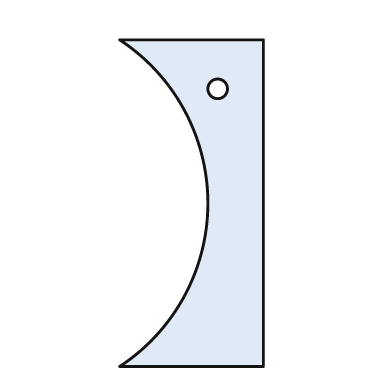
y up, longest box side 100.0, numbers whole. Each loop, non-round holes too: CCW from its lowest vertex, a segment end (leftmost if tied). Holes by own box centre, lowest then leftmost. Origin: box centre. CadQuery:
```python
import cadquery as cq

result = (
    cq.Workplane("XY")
    .moveTo(-22.0, -50.0)
    .lineTo(22.0, -50.0)
    .lineTo(22.0, 50.0)
    .lineTo(-22.0, 50.0)
    .threePointArc((5.0, 0.0), (-22.0, -50.0))
    .close()
    .moveTo(8.0, 35.0)
    .circle(3.0)
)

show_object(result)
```